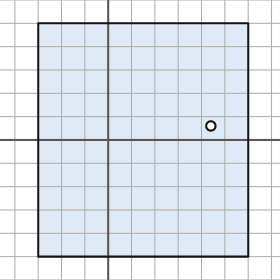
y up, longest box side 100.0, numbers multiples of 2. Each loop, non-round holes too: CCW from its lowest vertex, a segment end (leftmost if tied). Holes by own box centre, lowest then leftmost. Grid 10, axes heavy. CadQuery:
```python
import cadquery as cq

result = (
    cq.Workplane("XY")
    .moveTo(-30.0, -50.0)
    .lineTo(60.0, -50.0)
    .lineTo(60.0, 50.0)
    .lineTo(-30.0, 50.0)
    .close()
    .moveTo(44.0, 6.0)
    .circle(2.0)
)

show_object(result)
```